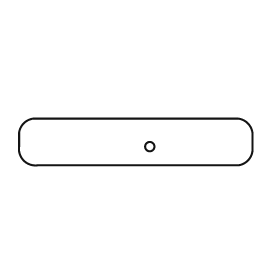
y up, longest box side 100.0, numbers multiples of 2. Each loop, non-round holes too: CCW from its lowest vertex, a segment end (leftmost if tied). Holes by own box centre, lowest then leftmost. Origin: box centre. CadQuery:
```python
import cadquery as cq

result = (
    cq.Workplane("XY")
    .moveTo(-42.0, -10.0)
    .lineTo(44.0, -10.0)
    .threePointArc((48.0, -8.0), (50.0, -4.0))
    .lineTo(50.0, 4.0)
    .threePointArc((48.0, 8.0), (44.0, 10.0))
    .lineTo(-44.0, 10.0)
    .threePointArc((-48.0, 8.0), (-50.0, 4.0))
    .lineTo(-50.0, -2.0)
    .threePointArc((-48.0, -8.0), (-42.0, -10.0))
    .close()
    .moveTo(6.0, -2.0)
    .circle(2.0)
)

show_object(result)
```